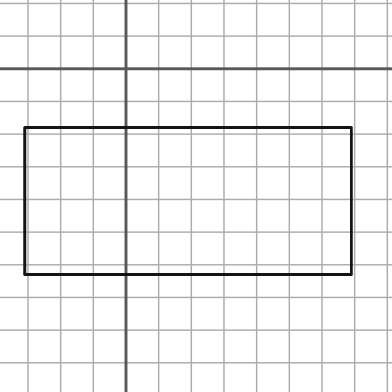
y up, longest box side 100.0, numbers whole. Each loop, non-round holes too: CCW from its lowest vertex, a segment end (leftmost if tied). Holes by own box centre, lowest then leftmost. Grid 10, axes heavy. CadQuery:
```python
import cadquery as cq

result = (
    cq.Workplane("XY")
    .moveTo(-31.0, -63.0)
    .lineTo(69.0, -63.0)
    .lineTo(69.0, -18.0)
    .lineTo(-31.0, -18.0)
    .close()
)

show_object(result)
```